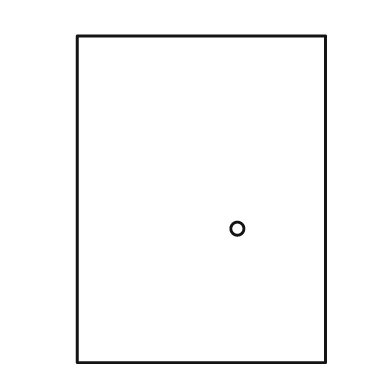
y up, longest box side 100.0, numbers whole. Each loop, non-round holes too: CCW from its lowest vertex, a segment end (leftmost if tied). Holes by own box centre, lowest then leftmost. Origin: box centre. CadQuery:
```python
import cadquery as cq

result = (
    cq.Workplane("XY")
    .moveTo(-38.0, -50.0)
    .lineTo(38.0, -50.0)
    .lineTo(38.0, 50.0)
    .lineTo(-38.0, 50.0)
    .close()
    .moveTo(11.0, -9.0)
    .circle(2.0)
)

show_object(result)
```